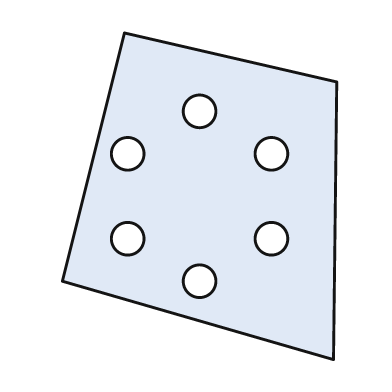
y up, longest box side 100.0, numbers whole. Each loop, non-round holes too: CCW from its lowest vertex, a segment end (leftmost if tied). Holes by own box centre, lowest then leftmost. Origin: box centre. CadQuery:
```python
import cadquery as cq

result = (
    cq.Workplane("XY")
    .moveTo(41.0, -50.0)
    .lineTo(42.0, 35.0)
    .lineTo(-23.0, 50.0)
    .lineTo(-42.0, -26.0)
    .close()
    .moveTo(0.0, -26.0)
    .circle(5.0)
    .moveTo(-22.0, -13.0)
    .circle(5.0)
    .moveTo(22.0, -13.0)
    .circle(5.0)
    .moveTo(-22.0, 13.0)
    .circle(5.0)
    .moveTo(22.0, 13.0)
    .circle(5.0)
    .moveTo(0.0, 26.0)
    .circle(5.0)
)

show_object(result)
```